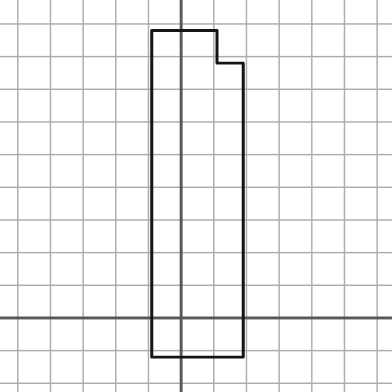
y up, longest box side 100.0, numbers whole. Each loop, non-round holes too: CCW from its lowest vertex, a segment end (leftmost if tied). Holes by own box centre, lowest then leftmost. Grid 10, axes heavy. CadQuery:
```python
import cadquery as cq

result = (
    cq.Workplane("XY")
    .moveTo(-9.0, -12.0)
    .lineTo(19.0, -12.0)
    .lineTo(19.0, 78.0)
    .lineTo(11.0, 78.0)
    .lineTo(11.0, 88.0)
    .lineTo(-9.0, 88.0)
    .close()
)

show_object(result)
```